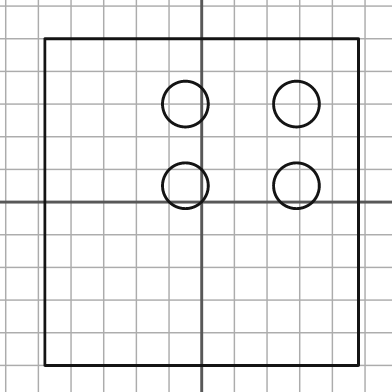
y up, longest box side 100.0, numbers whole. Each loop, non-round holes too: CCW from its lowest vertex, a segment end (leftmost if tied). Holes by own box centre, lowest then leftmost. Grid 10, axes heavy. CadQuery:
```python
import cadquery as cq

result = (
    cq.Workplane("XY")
    .moveTo(-48.0, -50.0)
    .lineTo(48.0, -50.0)
    .lineTo(48.0, 50.0)
    .lineTo(-48.0, 50.0)
    .close()
    .moveTo(-5.0, 5.0)
    .circle(7.0)
    .moveTo(29.0, 5.0)
    .circle(7.0)
    .moveTo(-5.0, 30.0)
    .circle(7.0)
    .moveTo(29.0, 30.0)
    .circle(7.0)
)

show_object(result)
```